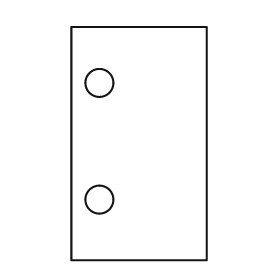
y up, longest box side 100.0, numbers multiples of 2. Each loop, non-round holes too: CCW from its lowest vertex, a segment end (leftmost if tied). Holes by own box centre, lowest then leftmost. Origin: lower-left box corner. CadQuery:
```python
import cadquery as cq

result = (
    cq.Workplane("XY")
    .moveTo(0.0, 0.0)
    .lineTo(58.0, 0.0)
    .lineTo(58.0, 100.0)
    .lineTo(0.0, 100.0)
    .close()
    .moveTo(12.0, 26.0)
    .circle(6.0)
    .moveTo(12.0, 76.0)
    .circle(6.0)
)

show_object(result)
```